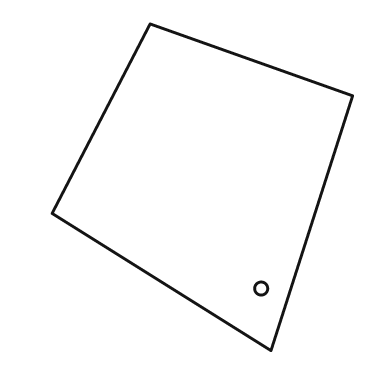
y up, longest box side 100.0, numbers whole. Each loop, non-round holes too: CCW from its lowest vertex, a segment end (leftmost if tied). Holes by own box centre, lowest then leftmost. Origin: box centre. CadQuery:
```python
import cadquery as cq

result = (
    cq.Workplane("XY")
    .moveTo(21.0, -50.0)
    .lineTo(46.0, 28.0)
    .lineTo(-16.0, 50.0)
    .lineTo(-46.0, -8.0)
    .close()
    .moveTo(18.0, -31.0)
    .circle(2.0)
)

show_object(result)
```